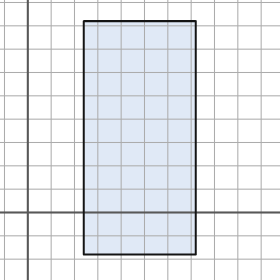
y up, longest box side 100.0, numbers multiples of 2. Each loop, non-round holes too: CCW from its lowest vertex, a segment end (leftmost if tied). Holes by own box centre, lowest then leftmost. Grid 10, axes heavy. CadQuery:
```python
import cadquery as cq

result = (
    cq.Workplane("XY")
    .moveTo(24.0, -18.0)
    .lineTo(72.0, -18.0)
    .lineTo(72.0, 82.0)
    .lineTo(24.0, 82.0)
    .close()
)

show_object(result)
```